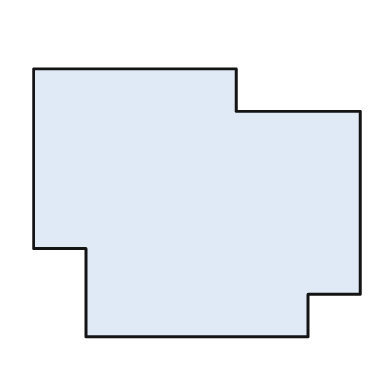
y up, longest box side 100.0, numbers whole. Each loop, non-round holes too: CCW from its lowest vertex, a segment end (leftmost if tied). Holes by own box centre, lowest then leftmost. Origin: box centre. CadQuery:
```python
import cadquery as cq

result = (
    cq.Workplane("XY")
    .moveTo(-34.0, -41.0)
    .lineTo(34.0, -41.0)
    .lineTo(34.0, -28.0)
    .lineTo(50.0, -28.0)
    .lineTo(50.0, 28.0)
    .lineTo(12.0, 28.0)
    .lineTo(12.0, 41.0)
    .lineTo(-50.0, 41.0)
    .lineTo(-50.0, -14.0)
    .lineTo(-34.0, -14.0)
    .close()
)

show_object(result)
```